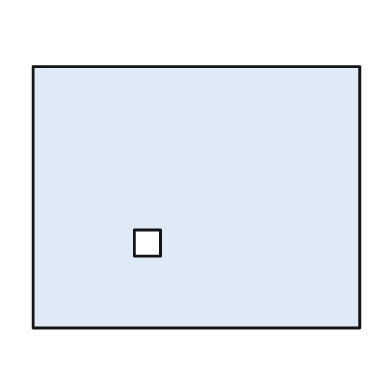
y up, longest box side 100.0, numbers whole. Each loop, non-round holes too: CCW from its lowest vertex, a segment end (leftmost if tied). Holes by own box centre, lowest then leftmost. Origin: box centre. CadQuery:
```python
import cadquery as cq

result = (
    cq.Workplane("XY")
    .moveTo(-50.0, -40.0)
    .lineTo(50.0, -40.0)
    .lineTo(50.0, 40.0)
    .lineTo(-50.0, 40.0)
    .close()
    .moveTo(-19.0, -18.0)
    .lineTo(-11.0, -18.0)
    .lineTo(-11.0, -10.0)
    .lineTo(-19.0, -10.0)
    .close()
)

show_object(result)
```